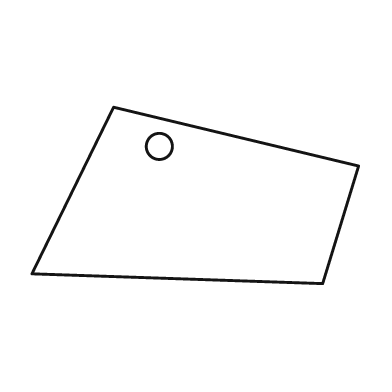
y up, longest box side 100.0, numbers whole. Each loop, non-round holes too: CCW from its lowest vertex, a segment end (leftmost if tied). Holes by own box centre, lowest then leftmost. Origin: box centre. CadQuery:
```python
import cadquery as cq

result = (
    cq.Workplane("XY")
    .moveTo(39.0, -27.0)
    .lineTo(50.0, 9.0)
    .lineTo(-25.0, 27.0)
    .lineTo(-50.0, -24.0)
    .close()
    .moveTo(-11.0, 15.0)
    .circle(4.0)
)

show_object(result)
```